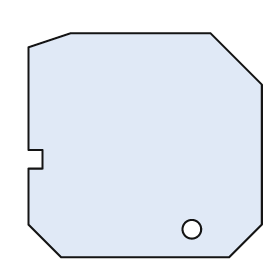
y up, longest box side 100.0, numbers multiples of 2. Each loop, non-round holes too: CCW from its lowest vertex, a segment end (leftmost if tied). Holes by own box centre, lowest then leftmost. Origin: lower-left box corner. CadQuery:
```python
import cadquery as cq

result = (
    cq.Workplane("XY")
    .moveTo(14.0, 0.0)
    .lineTo(86.0, 0.0)
    .lineTo(100.0, 14.0)
    .lineTo(100.0, 74.0)
    .lineTo(78.0, 96.0)
    .lineTo(18.0, 96.0)
    .lineTo(0.0, 90.0)
    .lineTo(0.0, 46.0)
    .lineTo(6.0, 46.0)
    .lineTo(6.0, 38.0)
    .lineTo(0.0, 38.0)
    .lineTo(0.0, 14.0)
    .close()
    .moveTo(70.0, 12.0)
    .circle(4.0)
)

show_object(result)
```